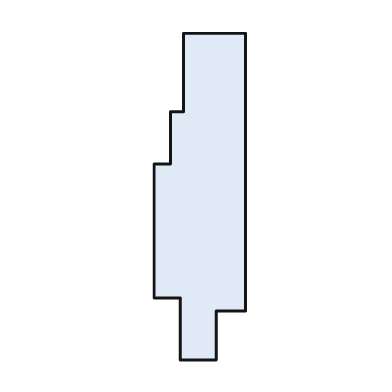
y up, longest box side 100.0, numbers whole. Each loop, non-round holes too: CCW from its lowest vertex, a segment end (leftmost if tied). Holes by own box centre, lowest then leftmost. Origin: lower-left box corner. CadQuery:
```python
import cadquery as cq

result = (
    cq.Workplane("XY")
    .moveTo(8.0, 0.0)
    .lineTo(19.0, 0.0)
    .lineTo(19.0, 15.0)
    .lineTo(28.0, 15.0)
    .lineTo(28.0, 100.0)
    .lineTo(9.0, 100.0)
    .lineTo(9.0, 76.0)
    .lineTo(5.0, 76.0)
    .lineTo(5.0, 60.0)
    .lineTo(0.0, 60.0)
    .lineTo(0.0, 19.0)
    .lineTo(8.0, 19.0)
    .close()
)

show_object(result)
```